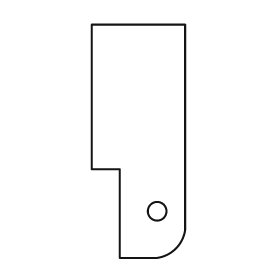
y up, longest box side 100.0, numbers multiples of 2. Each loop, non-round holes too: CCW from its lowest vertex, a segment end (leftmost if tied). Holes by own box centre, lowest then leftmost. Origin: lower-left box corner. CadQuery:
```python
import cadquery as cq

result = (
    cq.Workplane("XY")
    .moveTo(12.0, 0.0)
    .lineTo(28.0, 0.0)
    .threePointArc((36.0, 4.0), (40.0, 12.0))
    .lineTo(40.0, 100.0)
    .lineTo(0.0, 100.0)
    .lineTo(0.0, 38.0)
    .lineTo(12.0, 38.0)
    .close()
    .moveTo(28.0, 20.0)
    .circle(4.0)
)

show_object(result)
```